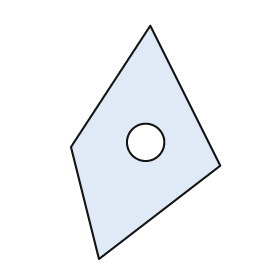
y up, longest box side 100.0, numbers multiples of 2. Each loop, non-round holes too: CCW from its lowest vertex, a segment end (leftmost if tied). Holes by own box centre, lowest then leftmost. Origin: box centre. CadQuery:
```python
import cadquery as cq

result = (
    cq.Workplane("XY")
    .moveTo(-20.0, -50.0)
    .lineTo(32.0, -10.0)
    .lineTo(2.0, 50.0)
    .lineTo(-32.0, -2.0)
    .close()
    .moveTo(0.0, 0.0)
    .circle(8.0)
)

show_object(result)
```